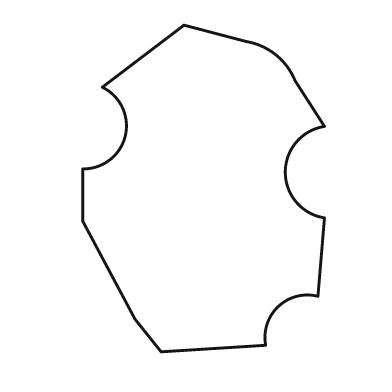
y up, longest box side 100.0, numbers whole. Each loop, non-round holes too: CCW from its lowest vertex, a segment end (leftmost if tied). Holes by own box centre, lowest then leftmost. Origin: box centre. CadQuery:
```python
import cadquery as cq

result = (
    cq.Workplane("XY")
    .moveTo(-13.0, -50.0)
    .lineTo(19.0, -48.0)
    .threePointArc((23.0, -36.0), (35.0, -33.0))
    .lineTo(37.0, -9.0)
    .threePointArc((25.0, 5.0), (37.0, 19.0))
    .lineTo(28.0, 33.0)
    .threePointArc((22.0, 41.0), (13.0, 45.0))
    .lineTo(-6.0, 50.0)
    .lineTo(-31.0, 31.0)
    .threePointArc((-24.0, 16.0), (-37.0, 6.0))
    .lineTo(-37.0, -10.0)
    .lineTo(-21.0, -40.0)
    .close()
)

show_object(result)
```